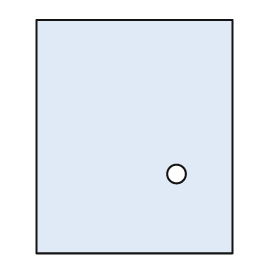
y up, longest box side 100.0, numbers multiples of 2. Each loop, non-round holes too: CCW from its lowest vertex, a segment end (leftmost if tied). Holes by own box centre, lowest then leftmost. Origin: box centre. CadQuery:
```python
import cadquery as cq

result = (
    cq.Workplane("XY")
    .moveTo(-42.0, -50.0)
    .lineTo(42.0, -50.0)
    .lineTo(42.0, 50.0)
    .lineTo(-42.0, 50.0)
    .close()
    .moveTo(18.0, -16.0)
    .circle(4.0)
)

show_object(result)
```